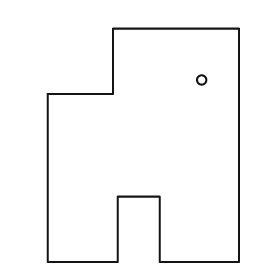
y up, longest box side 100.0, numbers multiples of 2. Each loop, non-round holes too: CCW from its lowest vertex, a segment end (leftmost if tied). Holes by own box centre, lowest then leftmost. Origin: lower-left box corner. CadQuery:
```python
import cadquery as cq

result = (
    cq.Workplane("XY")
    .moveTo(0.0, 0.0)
    .lineTo(30.0, 0.0)
    .lineTo(30.0, 28.0)
    .lineTo(48.0, 28.0)
    .lineTo(48.0, 0.0)
    .lineTo(82.0, 0.0)
    .lineTo(82.0, 100.0)
    .lineTo(28.0, 100.0)
    .lineTo(28.0, 72.0)
    .lineTo(0.0, 72.0)
    .close()
    .moveTo(66.0, 78.0)
    .circle(2.0)
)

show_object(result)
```